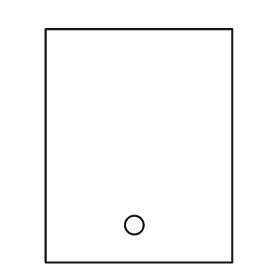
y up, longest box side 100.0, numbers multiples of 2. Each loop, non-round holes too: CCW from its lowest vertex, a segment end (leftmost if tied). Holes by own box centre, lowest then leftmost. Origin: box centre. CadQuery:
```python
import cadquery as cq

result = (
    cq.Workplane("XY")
    .moveTo(-40.0, -50.0)
    .lineTo(40.0, -50.0)
    .lineTo(40.0, 50.0)
    .lineTo(-40.0, 50.0)
    .close()
    .moveTo(-2.0, -34.0)
    .circle(4.0)
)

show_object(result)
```